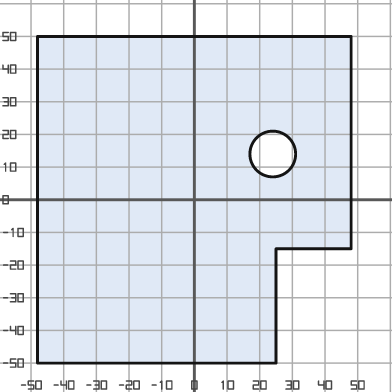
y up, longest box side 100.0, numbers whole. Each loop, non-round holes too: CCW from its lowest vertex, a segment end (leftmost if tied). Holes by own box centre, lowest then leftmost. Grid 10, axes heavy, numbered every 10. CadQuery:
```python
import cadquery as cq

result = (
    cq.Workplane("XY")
    .moveTo(-48.0, -50.0)
    .lineTo(25.0, -50.0)
    .lineTo(25.0, -15.0)
    .lineTo(48.0, -15.0)
    .lineTo(48.0, 50.0)
    .lineTo(-48.0, 50.0)
    .close()
    .moveTo(24.0, 14.0)
    .circle(7.0)
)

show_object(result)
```